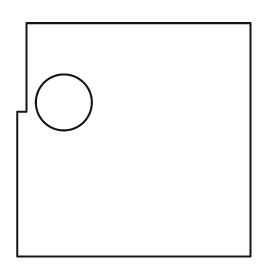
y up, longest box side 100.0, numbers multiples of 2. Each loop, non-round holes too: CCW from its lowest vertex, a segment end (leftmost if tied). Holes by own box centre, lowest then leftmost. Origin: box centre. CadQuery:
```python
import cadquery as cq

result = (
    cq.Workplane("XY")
    .moveTo(-50.0, -50.0)
    .lineTo(50.0, -50.0)
    .lineTo(50.0, 50.0)
    .lineTo(-46.0, 50.0)
    .lineTo(-46.0, 12.0)
    .lineTo(-50.0, 12.0)
    .close()
    .moveTo(-30.0, 16.0)
    .circle(12.0)
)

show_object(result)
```